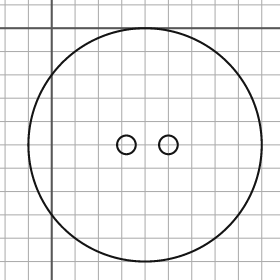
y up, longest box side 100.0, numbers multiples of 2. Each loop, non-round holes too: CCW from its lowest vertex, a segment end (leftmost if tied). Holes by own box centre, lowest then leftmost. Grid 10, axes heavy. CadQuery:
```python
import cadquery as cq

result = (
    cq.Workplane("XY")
    .moveTo(40.0, -50.0)
    .circle(50.0)
    .moveTo(32.0, -50.0)
    .circle(4.0)
    .moveTo(50.0, -50.0)
    .circle(4.0)
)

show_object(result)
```